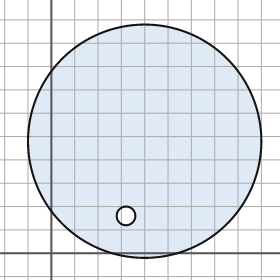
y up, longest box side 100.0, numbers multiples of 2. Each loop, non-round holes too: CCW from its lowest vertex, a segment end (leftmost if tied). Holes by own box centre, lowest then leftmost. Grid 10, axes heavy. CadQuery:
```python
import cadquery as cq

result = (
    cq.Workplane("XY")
    .moveTo(40.0, 48.0)
    .circle(50.0)
    .moveTo(32.0, 16.0)
    .circle(4.0)
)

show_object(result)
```